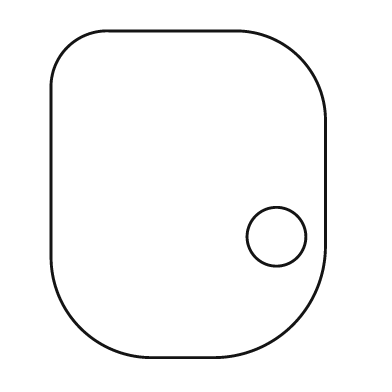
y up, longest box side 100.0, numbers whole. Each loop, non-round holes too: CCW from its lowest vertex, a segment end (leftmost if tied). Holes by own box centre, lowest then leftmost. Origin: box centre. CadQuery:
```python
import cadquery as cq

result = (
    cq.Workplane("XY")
    .moveTo(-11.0, -50.0)
    .lineTo(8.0, -50.0)
    .threePointArc((32.0, -40.0), (42.0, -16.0))
    .lineTo(42.0, 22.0)
    .threePointArc((34.0, 42.0), (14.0, 50.0))
    .lineTo(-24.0, 50.0)
    .threePointArc((-37.0, 45.0), (-42.0, 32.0))
    .lineTo(-42.0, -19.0)
    .threePointArc((-33.0, -41.0), (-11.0, -50.0))
    .close()
    .moveTo(27.0, -13.0)
    .circle(9.0)
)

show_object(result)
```